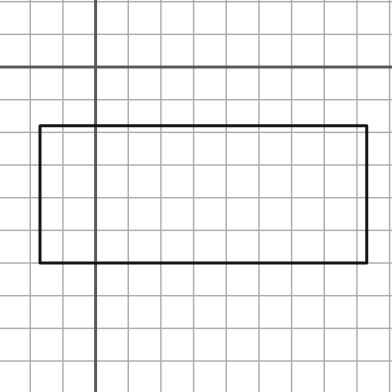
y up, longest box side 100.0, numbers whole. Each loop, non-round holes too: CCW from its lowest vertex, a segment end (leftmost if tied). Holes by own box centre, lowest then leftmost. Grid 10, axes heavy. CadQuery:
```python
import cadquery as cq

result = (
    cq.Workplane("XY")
    .moveTo(-17.0, -60.0)
    .lineTo(83.0, -60.0)
    .lineTo(83.0, -18.0)
    .lineTo(-17.0, -18.0)
    .close()
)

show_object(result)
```